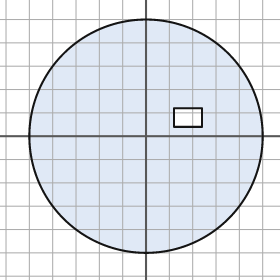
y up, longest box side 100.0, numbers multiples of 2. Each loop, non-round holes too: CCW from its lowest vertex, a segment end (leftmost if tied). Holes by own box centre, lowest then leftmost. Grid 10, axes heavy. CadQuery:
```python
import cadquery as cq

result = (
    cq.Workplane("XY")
    .moveTo(0.0, 0.0)
    .circle(50.0)
    .moveTo(12.0, 4.0)
    .lineTo(24.0, 4.0)
    .lineTo(24.0, 12.0)
    .lineTo(12.0, 12.0)
    .close()
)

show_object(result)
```